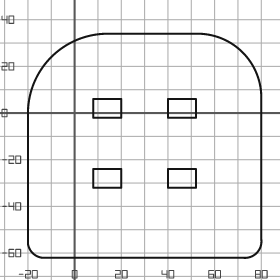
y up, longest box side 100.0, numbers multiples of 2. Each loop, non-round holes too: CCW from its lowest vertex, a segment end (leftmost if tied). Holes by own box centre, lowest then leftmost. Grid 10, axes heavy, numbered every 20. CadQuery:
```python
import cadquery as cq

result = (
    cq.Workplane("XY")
    .moveTo(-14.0, -62.0)
    .lineTo(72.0, -62.0)
    .threePointArc((78.0, -60.0), (80.0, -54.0))
    .lineTo(80.0, 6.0)
    .threePointArc((72.0, 26.0), (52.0, 34.0))
    .lineTo(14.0, 34.0)
    .threePointArc((-10.0, 24.0), (-20.0, 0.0))
    .lineTo(-20.0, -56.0)
    .threePointArc((-18.0, -60.0), (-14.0, -62.0))
    .close()
    .moveTo(8.0, -32.0)
    .lineTo(20.0, -32.0)
    .lineTo(20.0, -24.0)
    .lineTo(8.0, -24.0)
    .close()
    .moveTo(40.0, -32.0)
    .lineTo(52.0, -32.0)
    .lineTo(52.0, -24.0)
    .lineTo(40.0, -24.0)
    .close()
    .moveTo(8.0, -2.0)
    .lineTo(20.0, -2.0)
    .lineTo(20.0, 6.0)
    .lineTo(8.0, 6.0)
    .close()
    .moveTo(40.0, -2.0)
    .lineTo(52.0, -2.0)
    .lineTo(52.0, 6.0)
    .lineTo(40.0, 6.0)
    .close()
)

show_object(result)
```